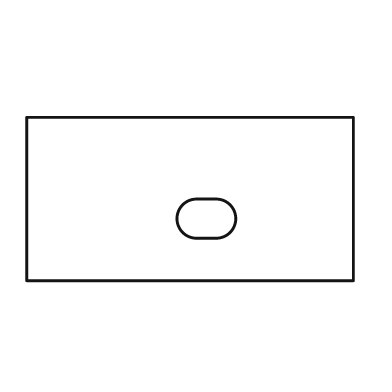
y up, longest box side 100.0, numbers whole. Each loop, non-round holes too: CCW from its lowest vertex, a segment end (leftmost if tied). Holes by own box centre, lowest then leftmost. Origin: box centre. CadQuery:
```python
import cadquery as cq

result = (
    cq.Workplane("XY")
    .moveTo(-50.0, -25.0)
    .lineTo(50.0, -25.0)
    .lineTo(50.0, 25.0)
    .lineTo(-50.0, 25.0)
    .close()
    .moveTo(2.0, -12.0)
    .lineTo(8.0, -12.0)
    .threePointArc((14.0, -6.0), (8.0, 0.0))
    .lineTo(2.0, 0.0)
    .threePointArc((-4.0, -6.0), (2.0, -12.0))
    .close()
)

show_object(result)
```